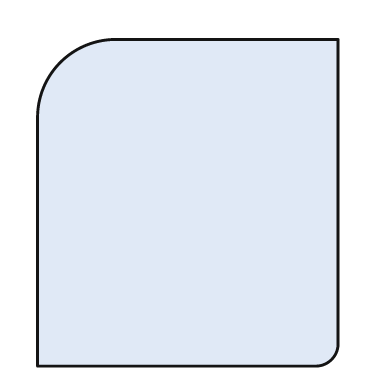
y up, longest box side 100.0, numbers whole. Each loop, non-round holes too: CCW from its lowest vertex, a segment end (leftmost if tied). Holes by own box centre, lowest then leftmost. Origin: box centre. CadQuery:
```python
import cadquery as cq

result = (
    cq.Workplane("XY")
    .moveTo(-46.0, -50.0)
    .lineTo(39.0, -50.0)
    .threePointArc((44.0, -48.0), (46.0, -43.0))
    .lineTo(46.0, 50.0)
    .lineTo(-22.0, 50.0)
    .threePointArc((-39.0, 43.0), (-46.0, 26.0))
    .close()
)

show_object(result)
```